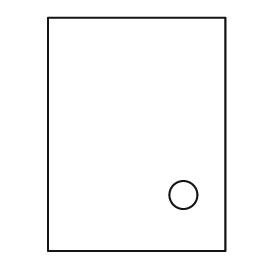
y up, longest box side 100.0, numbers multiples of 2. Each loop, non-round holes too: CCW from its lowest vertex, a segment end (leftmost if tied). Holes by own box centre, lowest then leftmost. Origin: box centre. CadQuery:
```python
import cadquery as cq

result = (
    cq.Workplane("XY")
    .moveTo(-38.0, -50.0)
    .lineTo(38.0, -50.0)
    .lineTo(38.0, 50.0)
    .lineTo(-38.0, 50.0)
    .close()
    .moveTo(20.0, -26.0)
    .circle(6.0)
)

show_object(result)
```